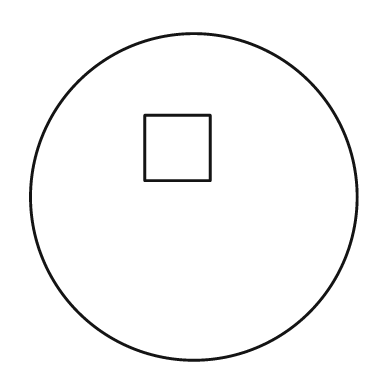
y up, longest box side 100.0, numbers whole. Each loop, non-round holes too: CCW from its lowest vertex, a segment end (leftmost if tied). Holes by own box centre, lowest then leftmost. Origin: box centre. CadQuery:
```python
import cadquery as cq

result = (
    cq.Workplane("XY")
    .moveTo(0.0, 0.0)
    .circle(50.0)
    .moveTo(-15.0, 5.0)
    .lineTo(5.0, 5.0)
    .lineTo(5.0, 25.0)
    .lineTo(-15.0, 25.0)
    .close()
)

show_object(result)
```